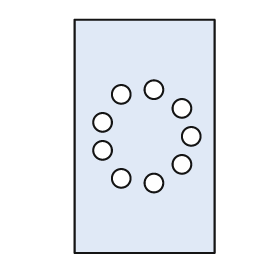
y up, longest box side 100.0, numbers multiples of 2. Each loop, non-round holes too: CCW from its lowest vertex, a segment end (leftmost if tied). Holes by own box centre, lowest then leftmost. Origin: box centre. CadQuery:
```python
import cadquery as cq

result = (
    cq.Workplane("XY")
    .moveTo(-30.0, -50.0)
    .lineTo(30.0, -50.0)
    .lineTo(30.0, 50.0)
    .lineTo(-30.0, 50.0)
    .close()
    .moveTo(4.0, -20.0)
    .circle(4.0)
    .moveTo(-10.0, -18.0)
    .circle(4.0)
    .moveTo(16.0, -12.0)
    .circle(4.0)
    .moveTo(-18.0, -6.0)
    .circle(4.0)
    .moveTo(20.0, 0.0)
    .circle(4.0)
    .moveTo(-18.0, 6.0)
    .circle(4.0)
    .moveTo(16.0, 12.0)
    .circle(4.0)
    .moveTo(-10.0, 18.0)
    .circle(4.0)
    .moveTo(4.0, 20.0)
    .circle(4.0)
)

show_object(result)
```